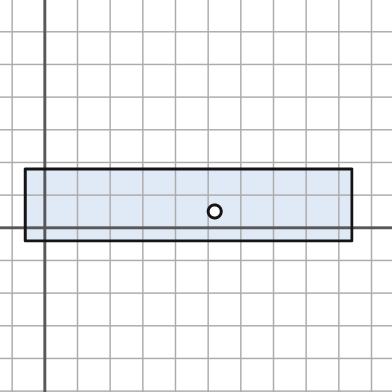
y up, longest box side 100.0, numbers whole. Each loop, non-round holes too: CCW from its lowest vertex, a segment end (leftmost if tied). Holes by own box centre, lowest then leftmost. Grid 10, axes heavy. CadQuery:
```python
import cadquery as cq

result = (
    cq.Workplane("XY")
    .moveTo(-6.0, -4.0)
    .lineTo(94.0, -4.0)
    .lineTo(94.0, 18.0)
    .lineTo(-6.0, 18.0)
    .close()
    .moveTo(52.0, 5.0)
    .circle(2.0)
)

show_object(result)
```